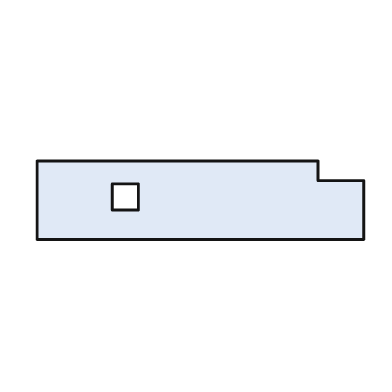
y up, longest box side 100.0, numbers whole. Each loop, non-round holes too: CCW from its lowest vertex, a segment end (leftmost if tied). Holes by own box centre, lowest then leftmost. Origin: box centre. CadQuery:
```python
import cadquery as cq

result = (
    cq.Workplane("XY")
    .moveTo(-50.0, -12.0)
    .lineTo(50.0, -12.0)
    .lineTo(50.0, 6.0)
    .lineTo(36.0, 6.0)
    .lineTo(36.0, 12.0)
    .lineTo(-50.0, 12.0)
    .close()
    .moveTo(-27.0, -3.0)
    .lineTo(-19.0, -3.0)
    .lineTo(-19.0, 5.0)
    .lineTo(-27.0, 5.0)
    .close()
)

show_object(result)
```